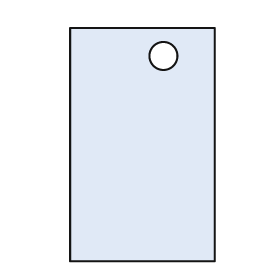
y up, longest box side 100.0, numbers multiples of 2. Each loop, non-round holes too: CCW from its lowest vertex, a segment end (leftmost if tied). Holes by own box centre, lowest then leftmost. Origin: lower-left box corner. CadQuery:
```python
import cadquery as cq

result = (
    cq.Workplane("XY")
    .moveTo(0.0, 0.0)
    .lineTo(62.0, 0.0)
    .lineTo(62.0, 100.0)
    .lineTo(0.0, 100.0)
    .close()
    .moveTo(40.0, 88.0)
    .circle(6.0)
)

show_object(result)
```